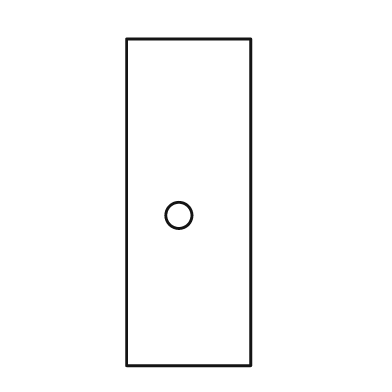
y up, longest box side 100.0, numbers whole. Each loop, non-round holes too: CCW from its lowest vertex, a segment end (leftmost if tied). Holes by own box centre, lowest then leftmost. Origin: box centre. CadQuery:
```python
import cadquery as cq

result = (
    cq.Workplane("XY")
    .moveTo(-19.0, -50.0)
    .lineTo(19.0, -50.0)
    .lineTo(19.0, 50.0)
    .lineTo(-19.0, 50.0)
    .close()
    .moveTo(-3.0, -4.0)
    .circle(4.0)
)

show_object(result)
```